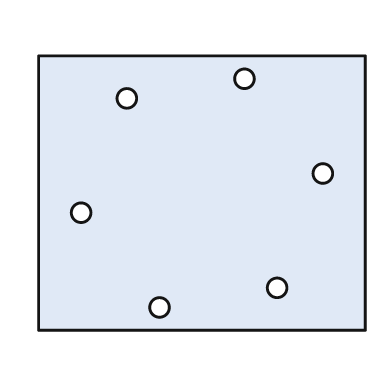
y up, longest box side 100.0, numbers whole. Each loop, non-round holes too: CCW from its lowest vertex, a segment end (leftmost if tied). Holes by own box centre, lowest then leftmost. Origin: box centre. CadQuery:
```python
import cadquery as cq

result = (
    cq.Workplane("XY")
    .moveTo(-50.0, -42.0)
    .lineTo(50.0, -42.0)
    .lineTo(50.0, 42.0)
    .lineTo(-50.0, 42.0)
    .close()
    .moveTo(-13.0, -35.0)
    .circle(3.0)
    .moveTo(23.0, -29.0)
    .circle(3.0)
    .moveTo(-37.0, -6.0)
    .circle(3.0)
    .moveTo(37.0, 6.0)
    .circle(3.0)
    .moveTo(-23.0, 29.0)
    .circle(3.0)
    .moveTo(13.0, 35.0)
    .circle(3.0)
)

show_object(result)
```